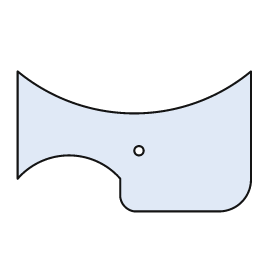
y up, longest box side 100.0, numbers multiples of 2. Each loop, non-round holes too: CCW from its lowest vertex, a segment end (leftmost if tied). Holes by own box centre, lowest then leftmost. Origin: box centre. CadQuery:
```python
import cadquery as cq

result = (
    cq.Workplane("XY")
    .moveTo(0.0, -30.0)
    .lineTo(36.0, -30.0)
    .threePointArc((46.0, -26.0), (50.0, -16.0))
    .lineTo(50.0, 30.0)
    .threePointArc((0.0, 12.0), (-50.0, 30.0))
    .lineTo(-50.0, -16.0)
    .threePointArc((-28.0, -6.0), (-6.0, -16.0))
    .lineTo(-6.0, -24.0)
    .threePointArc((-4.0, -28.0), (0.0, -30.0))
    .close()
    .moveTo(2.0, -4.0)
    .circle(2.0)
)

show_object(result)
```